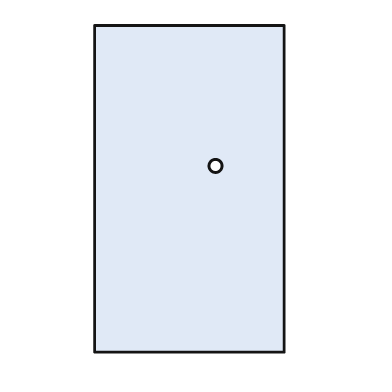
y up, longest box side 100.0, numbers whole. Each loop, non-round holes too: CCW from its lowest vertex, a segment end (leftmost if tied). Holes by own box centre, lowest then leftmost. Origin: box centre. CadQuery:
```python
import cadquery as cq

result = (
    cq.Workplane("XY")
    .moveTo(-29.0, -50.0)
    .lineTo(29.0, -50.0)
    .lineTo(29.0, 50.0)
    .lineTo(-29.0, 50.0)
    .close()
    .moveTo(8.0, 7.0)
    .circle(2.0)
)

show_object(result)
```